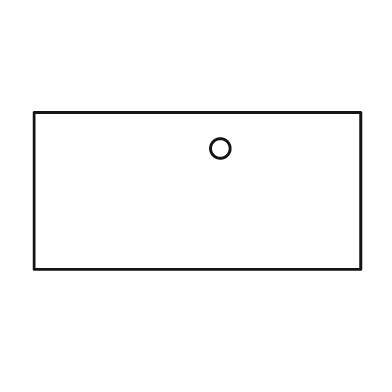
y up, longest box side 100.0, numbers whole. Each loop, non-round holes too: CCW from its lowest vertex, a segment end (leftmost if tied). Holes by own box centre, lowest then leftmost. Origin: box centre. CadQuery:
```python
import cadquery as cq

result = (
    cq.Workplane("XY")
    .moveTo(-50.0, -24.0)
    .lineTo(50.0, -24.0)
    .lineTo(50.0, 24.0)
    .lineTo(-50.0, 24.0)
    .close()
    .moveTo(7.0, 13.0)
    .circle(3.0)
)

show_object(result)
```